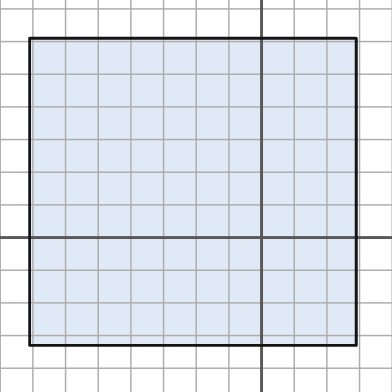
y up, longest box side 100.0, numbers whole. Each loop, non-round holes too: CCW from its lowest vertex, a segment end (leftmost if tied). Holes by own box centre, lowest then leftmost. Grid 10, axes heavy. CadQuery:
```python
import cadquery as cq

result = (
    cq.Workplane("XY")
    .moveTo(-71.0, -33.0)
    .lineTo(29.0, -33.0)
    .lineTo(29.0, 61.0)
    .lineTo(-71.0, 61.0)
    .close()
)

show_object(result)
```